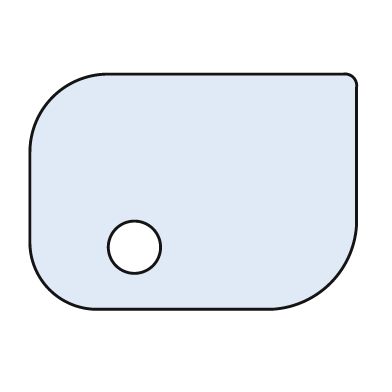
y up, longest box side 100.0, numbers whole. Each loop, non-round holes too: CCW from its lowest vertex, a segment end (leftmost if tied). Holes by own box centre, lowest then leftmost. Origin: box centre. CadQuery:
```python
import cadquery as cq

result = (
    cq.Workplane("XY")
    .moveTo(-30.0, -36.0)
    .lineTo(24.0, -36.0)
    .threePointArc((42.0, -28.0), (50.0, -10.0))
    .lineTo(50.0, 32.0)
    .threePointArc((49.0, 35.0), (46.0, 36.0))
    .lineTo(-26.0, 36.0)
    .threePointArc((-43.0, 29.0), (-50.0, 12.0))
    .lineTo(-50.0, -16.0)
    .threePointArc((-44.0, -30.0), (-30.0, -36.0))
    .close()
    .moveTo(-18.0, -17.0)
    .circle(8.0)
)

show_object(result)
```